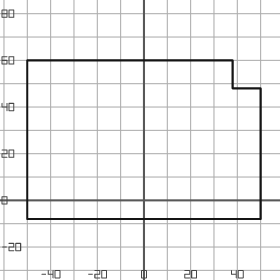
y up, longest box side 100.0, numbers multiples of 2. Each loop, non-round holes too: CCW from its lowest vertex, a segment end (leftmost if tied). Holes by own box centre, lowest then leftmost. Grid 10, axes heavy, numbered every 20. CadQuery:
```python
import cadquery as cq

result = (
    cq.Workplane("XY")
    .moveTo(-50.0, -8.0)
    .lineTo(50.0, -8.0)
    .lineTo(50.0, 48.0)
    .lineTo(38.0, 48.0)
    .lineTo(38.0, 60.0)
    .lineTo(-50.0, 60.0)
    .close()
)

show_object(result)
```